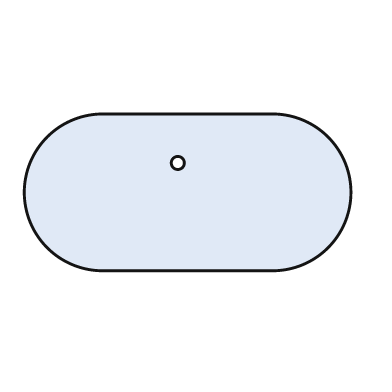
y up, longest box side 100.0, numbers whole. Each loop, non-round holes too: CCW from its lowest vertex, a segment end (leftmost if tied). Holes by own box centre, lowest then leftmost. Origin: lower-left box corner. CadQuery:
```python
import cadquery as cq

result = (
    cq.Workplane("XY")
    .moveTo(24.0, 0.0)
    .lineTo(76.0, 0.0)
    .threePointArc((100.0, 24.0), (76.0, 48.0))
    .lineTo(24.0, 48.0)
    .threePointArc((0.0, 24.0), (24.0, 0.0))
    .close()
    .moveTo(47.0, 33.0)
    .circle(2.0)
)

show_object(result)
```